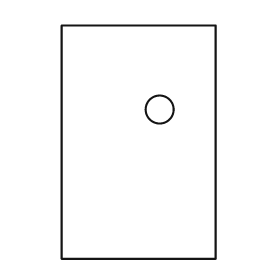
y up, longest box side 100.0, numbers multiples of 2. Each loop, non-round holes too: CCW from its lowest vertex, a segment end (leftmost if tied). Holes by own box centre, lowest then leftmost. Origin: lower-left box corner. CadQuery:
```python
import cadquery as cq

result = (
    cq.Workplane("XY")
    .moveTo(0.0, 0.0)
    .lineTo(66.0, 0.0)
    .lineTo(66.0, 100.0)
    .lineTo(0.0, 100.0)
    .close()
    .moveTo(42.0, 64.0)
    .circle(6.0)
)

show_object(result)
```